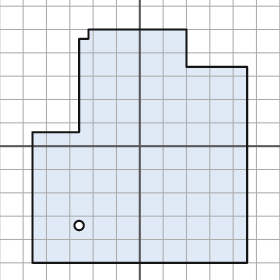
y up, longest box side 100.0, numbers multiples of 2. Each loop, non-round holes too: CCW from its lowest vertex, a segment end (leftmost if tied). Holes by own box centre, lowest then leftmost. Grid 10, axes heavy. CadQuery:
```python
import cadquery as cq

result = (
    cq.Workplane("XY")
    .moveTo(-46.0, -50.0)
    .lineTo(46.0, -50.0)
    .lineTo(46.0, 34.0)
    .lineTo(20.0, 34.0)
    .lineTo(20.0, 50.0)
    .lineTo(-22.0, 50.0)
    .lineTo(-22.0, 46.0)
    .lineTo(-26.0, 46.0)
    .lineTo(-26.0, 6.0)
    .lineTo(-46.0, 6.0)
    .close()
    .moveTo(-26.0, -34.0)
    .circle(2.0)
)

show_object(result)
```